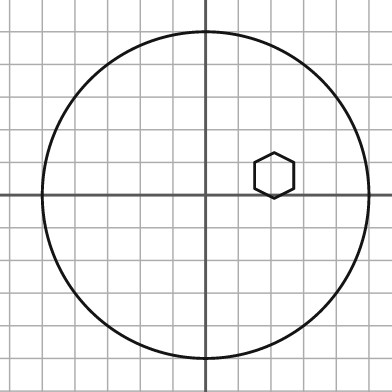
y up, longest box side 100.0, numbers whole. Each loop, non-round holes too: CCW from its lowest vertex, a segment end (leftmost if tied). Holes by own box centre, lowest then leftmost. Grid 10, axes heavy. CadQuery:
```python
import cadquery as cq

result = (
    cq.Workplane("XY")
    .moveTo(0.0, 0.0)
    .circle(50.0)
    .moveTo(21.0, -1.0)
    .lineTo(27.0, 2.0)
    .lineTo(27.0, 10.0)
    .lineTo(21.0, 13.0)
    .lineTo(15.0, 10.0)
    .lineTo(15.0, 2.0)
    .close()
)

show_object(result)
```